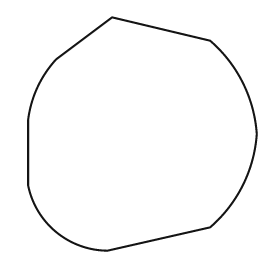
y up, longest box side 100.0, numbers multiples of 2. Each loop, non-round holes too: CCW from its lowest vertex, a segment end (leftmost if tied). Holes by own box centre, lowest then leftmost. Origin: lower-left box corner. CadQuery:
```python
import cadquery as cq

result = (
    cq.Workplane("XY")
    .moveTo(34.0, 0.0)
    .lineTo(78.0, 10.0)
    .threePointArc((92.0, 28.0), (98.0, 50.0))
    .threePointArc((92.0, 72.0), (78.0, 90.0))
    .lineTo(36.0, 100.0)
    .lineTo(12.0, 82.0)
    .threePointArc((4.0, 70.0), (0.0, 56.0))
    .lineTo(0.0, 28.0)
    .threePointArc((12.0, 8.0), (34.0, 0.0))
    .close()
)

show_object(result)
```